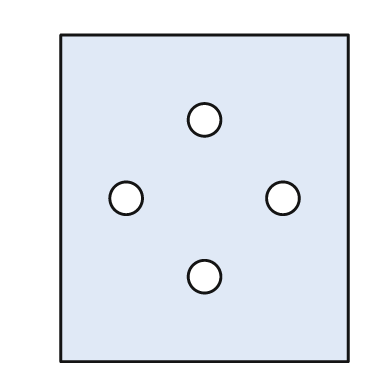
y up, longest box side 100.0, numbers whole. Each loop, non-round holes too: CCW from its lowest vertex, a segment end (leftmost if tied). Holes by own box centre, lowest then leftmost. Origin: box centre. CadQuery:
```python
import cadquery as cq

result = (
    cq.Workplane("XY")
    .moveTo(-44.0, -50.0)
    .lineTo(44.0, -50.0)
    .lineTo(44.0, 50.0)
    .lineTo(-44.0, 50.0)
    .close()
    .moveTo(0.0, -24.0)
    .circle(5.0)
    .moveTo(-24.0, 0.0)
    .circle(5.0)
    .moveTo(24.0, 0.0)
    .circle(5.0)
    .moveTo(0.0, 24.0)
    .circle(5.0)
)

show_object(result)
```